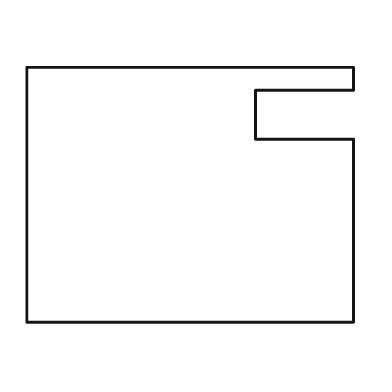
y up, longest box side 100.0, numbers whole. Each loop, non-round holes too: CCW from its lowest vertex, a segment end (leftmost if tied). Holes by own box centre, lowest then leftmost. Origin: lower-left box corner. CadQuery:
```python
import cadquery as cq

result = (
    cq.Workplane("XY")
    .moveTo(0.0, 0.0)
    .lineTo(100.0, 0.0)
    .lineTo(100.0, 56.0)
    .lineTo(70.0, 56.0)
    .lineTo(70.0, 71.0)
    .lineTo(100.0, 71.0)
    .lineTo(100.0, 78.0)
    .lineTo(0.0, 78.0)
    .close()
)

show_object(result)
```